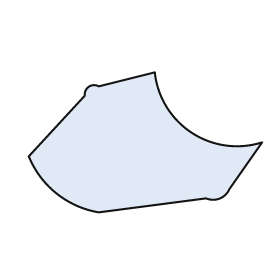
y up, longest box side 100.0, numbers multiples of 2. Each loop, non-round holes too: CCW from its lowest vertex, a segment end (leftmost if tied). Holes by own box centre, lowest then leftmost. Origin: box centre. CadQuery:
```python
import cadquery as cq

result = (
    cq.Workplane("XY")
    .moveTo(-20.0, -30.0)
    .lineTo(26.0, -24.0)
    .threePointArc((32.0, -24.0), (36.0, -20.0))
    .lineTo(50.0, 0.0)
    .threePointArc((20.0, 4.0), (4.0, 30.0))
    .lineTo(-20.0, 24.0)
    .threePointArc((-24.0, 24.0), (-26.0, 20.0))
    .lineTo(-50.0, -6.0)
    .threePointArc((-38.0, -22.0), (-20.0, -30.0))
    .close()
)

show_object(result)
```